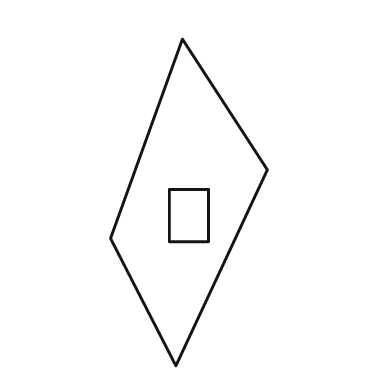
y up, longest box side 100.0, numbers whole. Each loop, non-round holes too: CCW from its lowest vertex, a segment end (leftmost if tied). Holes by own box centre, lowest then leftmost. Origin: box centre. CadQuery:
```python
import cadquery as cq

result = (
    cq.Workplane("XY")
    .moveTo(-4.0, -50.0)
    .lineTo(24.0, 10.0)
    .lineTo(-2.0, 50.0)
    .lineTo(-24.0, -11.0)
    .close()
    .moveTo(-6.0, -12.0)
    .lineTo(6.0, -12.0)
    .lineTo(6.0, 4.0)
    .lineTo(-6.0, 4.0)
    .close()
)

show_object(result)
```